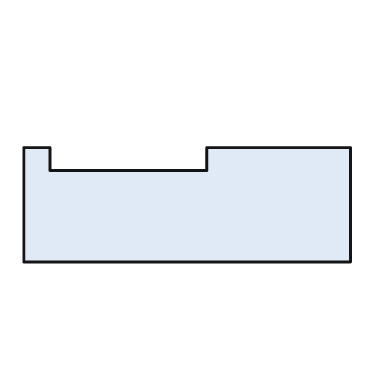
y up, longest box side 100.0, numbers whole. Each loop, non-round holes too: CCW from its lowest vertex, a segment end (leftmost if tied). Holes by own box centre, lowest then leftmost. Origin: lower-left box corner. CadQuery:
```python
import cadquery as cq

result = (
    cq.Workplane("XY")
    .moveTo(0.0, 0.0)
    .lineTo(100.0, 0.0)
    .lineTo(100.0, 35.0)
    .lineTo(56.0, 35.0)
    .lineTo(56.0, 28.0)
    .lineTo(8.0, 28.0)
    .lineTo(8.0, 35.0)
    .lineTo(0.0, 35.0)
    .close()
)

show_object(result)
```